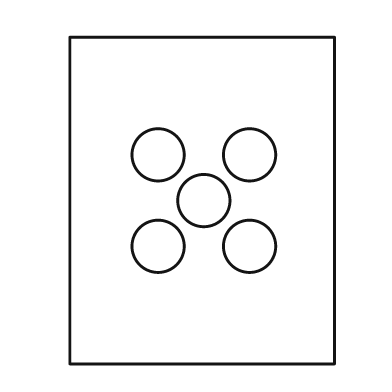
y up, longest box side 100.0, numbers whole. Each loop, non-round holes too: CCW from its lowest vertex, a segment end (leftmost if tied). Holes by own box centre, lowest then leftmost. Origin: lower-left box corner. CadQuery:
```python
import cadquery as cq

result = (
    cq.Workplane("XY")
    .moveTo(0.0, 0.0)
    .lineTo(81.0, 0.0)
    .lineTo(81.0, 100.0)
    .lineTo(0.0, 100.0)
    .close()
    .moveTo(27.0, 36.0)
    .circle(8.0)
    .moveTo(55.0, 36.0)
    .circle(8.0)
    .moveTo(41.0, 50.0)
    .circle(8.0)
    .moveTo(27.0, 64.0)
    .circle(8.0)
    .moveTo(55.0, 64.0)
    .circle(8.0)
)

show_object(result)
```